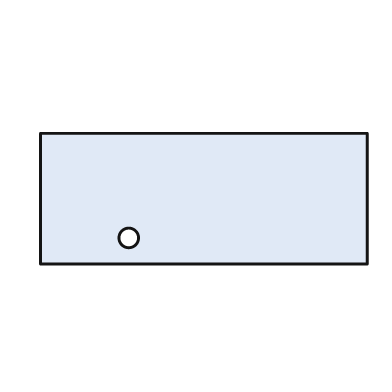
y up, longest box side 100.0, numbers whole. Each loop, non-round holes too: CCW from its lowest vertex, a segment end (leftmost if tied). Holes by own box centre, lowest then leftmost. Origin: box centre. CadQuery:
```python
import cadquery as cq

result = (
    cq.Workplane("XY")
    .moveTo(-50.0, -20.0)
    .lineTo(50.0, -20.0)
    .lineTo(50.0, 20.0)
    .lineTo(-50.0, 20.0)
    .close()
    .moveTo(-23.0, -12.0)
    .circle(3.0)
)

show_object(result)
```